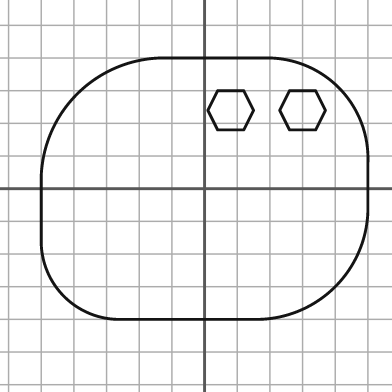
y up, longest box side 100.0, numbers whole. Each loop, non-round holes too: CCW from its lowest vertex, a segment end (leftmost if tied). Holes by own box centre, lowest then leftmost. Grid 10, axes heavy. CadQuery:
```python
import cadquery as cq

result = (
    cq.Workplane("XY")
    .moveTo(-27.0, -40.0)
    .lineTo(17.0, -40.0)
    .threePointArc((40.0, -30.0), (50.0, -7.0))
    .lineTo(50.0, 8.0)
    .threePointArc((41.0, 31.0), (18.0, 40.0))
    .lineTo(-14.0, 40.0)
    .threePointArc((-39.0, 29.0), (-50.0, 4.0))
    .lineTo(-50.0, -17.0)
    .threePointArc((-43.0, -33.0), (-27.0, -40.0))
    .close()
    .moveTo(4.0, 18.0)
    .lineTo(12.0, 18.0)
    .lineTo(15.0, 24.0)
    .lineTo(12.0, 30.0)
    .lineTo(4.0, 30.0)
    .lineTo(1.0, 24.0)
    .close()
    .moveTo(26.0, 18.0)
    .lineTo(34.0, 18.0)
    .lineTo(37.0, 24.0)
    .lineTo(34.0, 30.0)
    .lineTo(26.0, 30.0)
    .lineTo(23.0, 24.0)
    .close()
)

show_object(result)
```